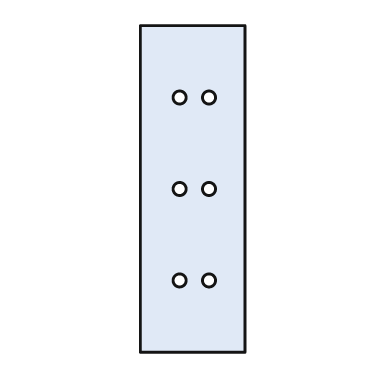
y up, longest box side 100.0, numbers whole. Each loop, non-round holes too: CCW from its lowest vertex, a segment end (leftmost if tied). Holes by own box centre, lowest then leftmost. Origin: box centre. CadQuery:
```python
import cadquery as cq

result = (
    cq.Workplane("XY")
    .moveTo(-16.0, -50.0)
    .lineTo(16.0, -50.0)
    .lineTo(16.0, 50.0)
    .lineTo(-16.0, 50.0)
    .close()
    .moveTo(-4.0, -28.0)
    .circle(2.0)
    .moveTo(5.0, -28.0)
    .circle(2.0)
    .moveTo(-4.0, 0.0)
    .circle(2.0)
    .moveTo(5.0, 0.0)
    .circle(2.0)
    .moveTo(-4.0, 28.0)
    .circle(2.0)
    .moveTo(5.0, 28.0)
    .circle(2.0)
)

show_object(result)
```